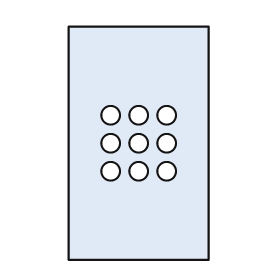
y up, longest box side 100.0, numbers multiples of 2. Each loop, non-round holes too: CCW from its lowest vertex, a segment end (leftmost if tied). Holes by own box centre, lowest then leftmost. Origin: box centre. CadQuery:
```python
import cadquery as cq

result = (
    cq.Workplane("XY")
    .moveTo(-30.0, -50.0)
    .lineTo(30.0, -50.0)
    .lineTo(30.0, 50.0)
    .lineTo(-30.0, 50.0)
    .close()
    .moveTo(-12.0, -12.0)
    .circle(4.0)
    .moveTo(0.0, -12.0)
    .circle(4.0)
    .moveTo(12.0, -12.0)
    .circle(4.0)
    .moveTo(-12.0, 0.0)
    .circle(4.0)
    .moveTo(0.0, 0.0)
    .circle(4.0)
    .moveTo(12.0, 0.0)
    .circle(4.0)
    .moveTo(-12.0, 12.0)
    .circle(4.0)
    .moveTo(0.0, 12.0)
    .circle(4.0)
    .moveTo(12.0, 12.0)
    .circle(4.0)
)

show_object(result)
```